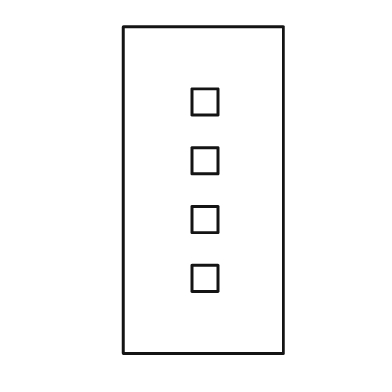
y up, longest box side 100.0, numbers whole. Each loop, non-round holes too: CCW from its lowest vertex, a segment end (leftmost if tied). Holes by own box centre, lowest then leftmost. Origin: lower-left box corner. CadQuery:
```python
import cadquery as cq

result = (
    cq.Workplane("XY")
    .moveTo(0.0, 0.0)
    .lineTo(49.0, 0.0)
    .lineTo(49.0, 100.0)
    .lineTo(0.0, 100.0)
    .close()
    .moveTo(21.0, 19.0)
    .lineTo(29.0, 19.0)
    .lineTo(29.0, 27.0)
    .lineTo(21.0, 27.0)
    .close()
    .moveTo(21.0, 37.0)
    .lineTo(29.0, 37.0)
    .lineTo(29.0, 45.0)
    .lineTo(21.0, 45.0)
    .close()
    .moveTo(21.0, 55.0)
    .lineTo(29.0, 55.0)
    .lineTo(29.0, 63.0)
    .lineTo(21.0, 63.0)
    .close()
    .moveTo(21.0, 73.0)
    .lineTo(29.0, 73.0)
    .lineTo(29.0, 81.0)
    .lineTo(21.0, 81.0)
    .close()
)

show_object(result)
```